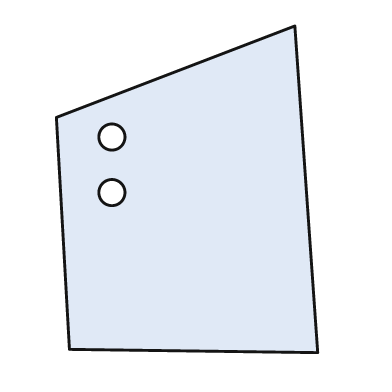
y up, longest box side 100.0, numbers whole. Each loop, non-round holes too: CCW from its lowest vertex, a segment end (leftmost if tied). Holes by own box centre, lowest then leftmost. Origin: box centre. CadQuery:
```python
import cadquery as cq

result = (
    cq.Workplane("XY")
    .moveTo(40.0, -50.0)
    .lineTo(33.0, 50.0)
    .lineTo(-40.0, 22.0)
    .lineTo(-36.0, -49.0)
    .close()
    .moveTo(-23.0, -1.0)
    .circle(4.0)
    .moveTo(-23.0, 16.0)
    .circle(4.0)
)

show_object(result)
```